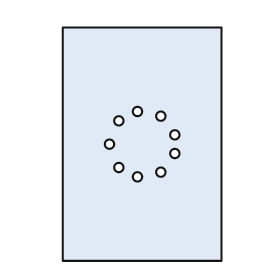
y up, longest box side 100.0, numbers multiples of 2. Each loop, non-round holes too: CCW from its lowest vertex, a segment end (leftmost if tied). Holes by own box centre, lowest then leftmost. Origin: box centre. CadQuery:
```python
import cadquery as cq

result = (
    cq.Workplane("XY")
    .moveTo(-34.0, -50.0)
    .lineTo(34.0, -50.0)
    .lineTo(34.0, 50.0)
    .lineTo(-34.0, 50.0)
    .close()
    .moveTo(-2.0, -14.0)
    .circle(2.0)
    .moveTo(8.0, -12.0)
    .circle(2.0)
    .moveTo(-10.0, -10.0)
    .circle(2.0)
    .moveTo(14.0, -4.0)
    .circle(2.0)
    .moveTo(-14.0, 0.0)
    .circle(2.0)
    .moveTo(14.0, 4.0)
    .circle(2.0)
    .moveTo(-10.0, 10.0)
    .circle(2.0)
    .moveTo(8.0, 12.0)
    .circle(2.0)
    .moveTo(-2.0, 14.0)
    .circle(2.0)
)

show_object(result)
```